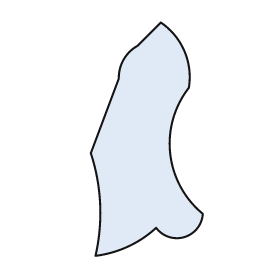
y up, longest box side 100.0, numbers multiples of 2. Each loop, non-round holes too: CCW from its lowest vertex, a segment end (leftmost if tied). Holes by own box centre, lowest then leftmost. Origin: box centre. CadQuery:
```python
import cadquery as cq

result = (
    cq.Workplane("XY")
    .moveTo(-22.0, -50.0)
    .threePointArc((-8.0, -46.0), (4.0, -38.0))
    .threePointArc((16.0, -42.0), (24.0, -32.0))
    .threePointArc((10.0, -6.0), (18.0, 22.0))
    .threePointArc((16.0, 38.0), (6.0, 50.0))
    .lineTo(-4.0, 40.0)
    .threePointArc((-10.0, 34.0), (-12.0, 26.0))
    .lineTo(-24.0, -6.0)
    .threePointArc((-20.0, -28.0), (-22.0, -50.0))
    .close()
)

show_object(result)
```